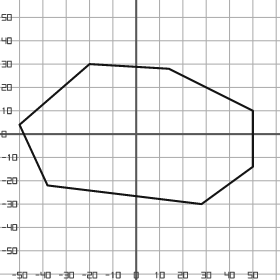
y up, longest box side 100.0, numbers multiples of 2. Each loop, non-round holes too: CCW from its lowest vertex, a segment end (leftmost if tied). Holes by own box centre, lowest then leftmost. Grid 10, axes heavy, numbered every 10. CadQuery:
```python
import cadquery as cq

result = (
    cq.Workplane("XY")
    .moveTo(28.0, -30.0)
    .lineTo(50.0, -14.0)
    .lineTo(50.0, 10.0)
    .lineTo(14.0, 28.0)
    .lineTo(-20.0, 30.0)
    .lineTo(-50.0, 4.0)
    .lineTo(-38.0, -22.0)
    .close()
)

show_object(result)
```